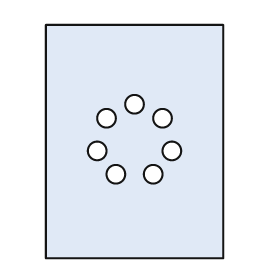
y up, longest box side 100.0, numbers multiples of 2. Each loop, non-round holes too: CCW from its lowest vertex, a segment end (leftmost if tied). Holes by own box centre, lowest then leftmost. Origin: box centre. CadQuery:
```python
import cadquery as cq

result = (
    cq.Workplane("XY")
    .moveTo(-38.0, -50.0)
    .lineTo(38.0, -50.0)
    .lineTo(38.0, 50.0)
    .lineTo(-38.0, 50.0)
    .close()
    .moveTo(-8.0, -14.0)
    .circle(4.0)
    .moveTo(8.0, -14.0)
    .circle(4.0)
    .moveTo(-16.0, -4.0)
    .circle(4.0)
    .moveTo(16.0, -4.0)
    .circle(4.0)
    .moveTo(-12.0, 10.0)
    .circle(4.0)
    .moveTo(12.0, 10.0)
    .circle(4.0)
    .moveTo(0.0, 16.0)
    .circle(4.0)
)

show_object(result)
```